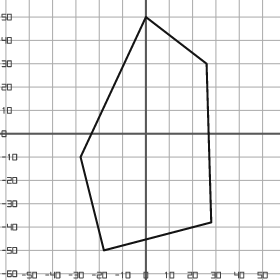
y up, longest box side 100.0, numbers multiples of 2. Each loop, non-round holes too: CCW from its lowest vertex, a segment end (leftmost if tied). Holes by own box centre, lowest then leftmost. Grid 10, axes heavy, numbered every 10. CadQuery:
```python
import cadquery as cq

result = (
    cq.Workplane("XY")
    .moveTo(-18.0, -50.0)
    .lineTo(28.0, -38.0)
    .lineTo(26.0, 30.0)
    .lineTo(0.0, 50.0)
    .lineTo(-28.0, -10.0)
    .close()
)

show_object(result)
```